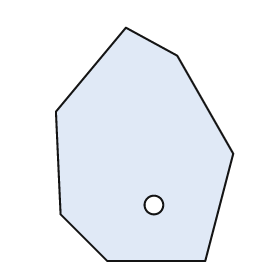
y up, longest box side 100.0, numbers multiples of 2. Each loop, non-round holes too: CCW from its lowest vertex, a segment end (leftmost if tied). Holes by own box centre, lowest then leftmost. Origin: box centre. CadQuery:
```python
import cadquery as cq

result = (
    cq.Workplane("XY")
    .moveTo(-16.0, -50.0)
    .lineTo(26.0, -50.0)
    .lineTo(38.0, -4.0)
    .lineTo(14.0, 38.0)
    .lineTo(-8.0, 50.0)
    .lineTo(-38.0, 14.0)
    .lineTo(-36.0, -30.0)
    .close()
    .moveTo(4.0, -26.0)
    .circle(4.0)
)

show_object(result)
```